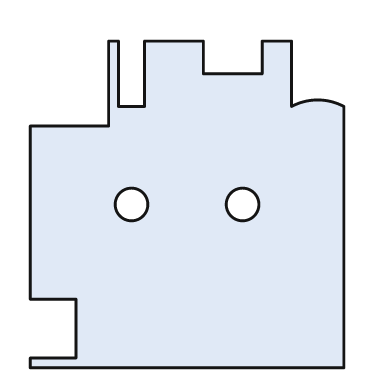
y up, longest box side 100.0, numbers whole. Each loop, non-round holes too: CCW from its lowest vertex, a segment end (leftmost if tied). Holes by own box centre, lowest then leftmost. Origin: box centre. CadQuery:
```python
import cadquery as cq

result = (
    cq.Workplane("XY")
    .moveTo(-48.0, -50.0)
    .lineTo(48.0, -50.0)
    .lineTo(48.0, 30.0)
    .threePointArc((40.0, 32.0), (32.0, 30.0))
    .lineTo(32.0, 50.0)
    .lineTo(23.0, 50.0)
    .lineTo(23.0, 40.0)
    .lineTo(5.0, 40.0)
    .lineTo(5.0, 50.0)
    .lineTo(-13.0, 50.0)
    .lineTo(-13.0, 30.0)
    .lineTo(-21.0, 30.0)
    .lineTo(-21.0, 50.0)
    .lineTo(-24.0, 50.0)
    .lineTo(-24.0, 24.0)
    .lineTo(-48.0, 24.0)
    .lineTo(-48.0, -29.0)
    .lineTo(-34.0, -29.0)
    .lineTo(-34.0, -47.0)
    .lineTo(-48.0, -47.0)
    .close()
    .moveTo(-17.0, 0.0)
    .circle(5.0)
    .moveTo(17.0, 0.0)
    .circle(5.0)
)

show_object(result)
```